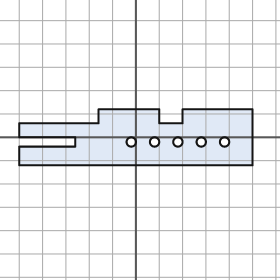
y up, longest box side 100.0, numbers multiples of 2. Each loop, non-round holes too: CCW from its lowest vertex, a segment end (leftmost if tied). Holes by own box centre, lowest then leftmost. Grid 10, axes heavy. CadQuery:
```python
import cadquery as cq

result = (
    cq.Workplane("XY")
    .moveTo(-50.0, -12.0)
    .lineTo(50.0, -12.0)
    .lineTo(50.0, 12.0)
    .lineTo(20.0, 12.0)
    .lineTo(20.0, 6.0)
    .lineTo(10.0, 6.0)
    .lineTo(10.0, 12.0)
    .lineTo(-16.0, 12.0)
    .lineTo(-16.0, 6.0)
    .lineTo(-50.0, 6.0)
    .lineTo(-50.0, 0.0)
    .lineTo(-26.0, 0.0)
    .lineTo(-26.0, -4.0)
    .lineTo(-50.0, -4.0)
    .close()
    .moveTo(-2.0, -2.0)
    .circle(2.0)
    .moveTo(8.0, -2.0)
    .circle(2.0)
    .moveTo(18.0, -2.0)
    .circle(2.0)
    .moveTo(28.0, -2.0)
    .circle(2.0)
    .moveTo(38.0, -2.0)
    .circle(2.0)
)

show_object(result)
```